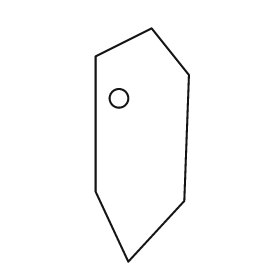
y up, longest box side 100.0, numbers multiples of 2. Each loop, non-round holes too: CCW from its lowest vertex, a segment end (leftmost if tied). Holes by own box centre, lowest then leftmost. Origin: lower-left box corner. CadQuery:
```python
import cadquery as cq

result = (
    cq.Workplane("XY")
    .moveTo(14.0, 0.0)
    .lineTo(38.0, 26.0)
    .lineTo(40.0, 80.0)
    .lineTo(24.0, 100.0)
    .lineTo(0.0, 88.0)
    .lineTo(0.0, 30.0)
    .close()
    .moveTo(10.0, 70.0)
    .circle(4.0)
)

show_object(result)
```